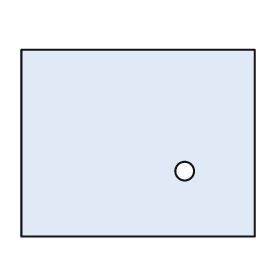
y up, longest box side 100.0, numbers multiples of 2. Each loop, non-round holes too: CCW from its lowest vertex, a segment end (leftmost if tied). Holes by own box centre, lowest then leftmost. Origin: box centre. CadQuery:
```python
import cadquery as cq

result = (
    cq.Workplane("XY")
    .moveTo(-50.0, -40.0)
    .lineTo(50.0, -40.0)
    .lineTo(50.0, 40.0)
    .lineTo(-50.0, 40.0)
    .close()
    .moveTo(20.0, -12.0)
    .circle(4.0)
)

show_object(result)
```